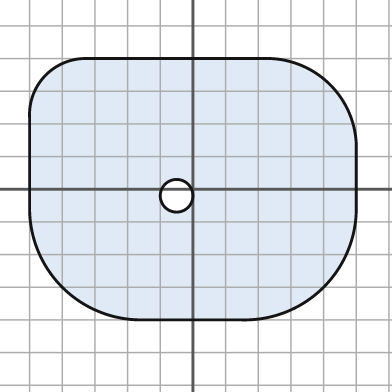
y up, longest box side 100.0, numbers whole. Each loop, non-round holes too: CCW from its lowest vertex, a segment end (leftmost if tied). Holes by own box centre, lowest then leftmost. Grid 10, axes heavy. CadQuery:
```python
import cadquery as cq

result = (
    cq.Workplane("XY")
    .moveTo(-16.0, -40.0)
    .lineTo(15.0, -40.0)
    .threePointArc((40.0, -30.0), (50.0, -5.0))
    .lineTo(50.0, 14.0)
    .threePointArc((42.0, 32.0), (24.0, 40.0))
    .lineTo(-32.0, 40.0)
    .threePointArc((-45.0, 35.0), (-50.0, 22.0))
    .lineTo(-50.0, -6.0)
    .threePointArc((-40.0, -30.0), (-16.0, -40.0))
    .close()
    .moveTo(-5.0, -2.0)
    .circle(5.0)
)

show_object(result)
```